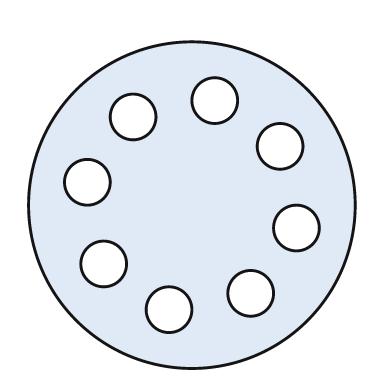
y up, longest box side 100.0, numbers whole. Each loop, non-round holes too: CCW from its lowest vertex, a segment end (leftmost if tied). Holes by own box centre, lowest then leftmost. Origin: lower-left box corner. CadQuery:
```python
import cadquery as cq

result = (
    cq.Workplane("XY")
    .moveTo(50.0, 50.0)
    .circle(50.0)
    .moveTo(43.0, 18.0)
    .circle(7.0)
    .moveTo(68.0, 23.0)
    .circle(7.0)
    .moveTo(23.0, 32.0)
    .circle(7.0)
    .moveTo(82.0, 43.0)
    .circle(7.0)
    .moveTo(18.0, 57.0)
    .circle(7.0)
    .moveTo(77.0, 68.0)
    .circle(7.0)
    .moveTo(32.0, 77.0)
    .circle(7.0)
    .moveTo(57.0, 82.0)
    .circle(7.0)
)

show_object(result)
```